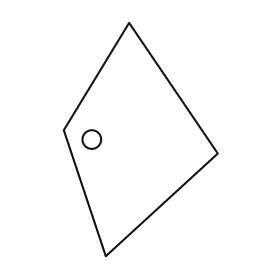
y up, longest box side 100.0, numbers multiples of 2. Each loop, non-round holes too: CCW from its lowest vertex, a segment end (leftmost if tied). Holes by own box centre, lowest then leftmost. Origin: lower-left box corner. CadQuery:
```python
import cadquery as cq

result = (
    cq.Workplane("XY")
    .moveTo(18.0, 0.0)
    .lineTo(66.0, 44.0)
    .lineTo(28.0, 100.0)
    .lineTo(0.0, 54.0)
    .close()
    .moveTo(12.0, 50.0)
    .circle(4.0)
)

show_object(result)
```